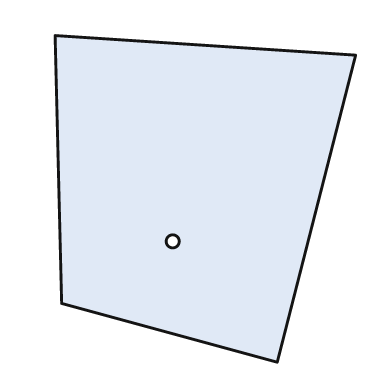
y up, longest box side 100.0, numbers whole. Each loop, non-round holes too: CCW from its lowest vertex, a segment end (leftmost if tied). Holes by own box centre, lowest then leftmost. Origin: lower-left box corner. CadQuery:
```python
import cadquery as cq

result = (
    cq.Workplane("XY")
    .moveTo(68.0, 0.0)
    .lineTo(92.0, 94.0)
    .lineTo(0.0, 100.0)
    .lineTo(2.0, 18.0)
    .close()
    .moveTo(36.0, 37.0)
    .circle(2.0)
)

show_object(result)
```